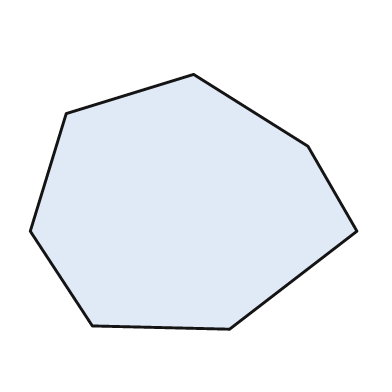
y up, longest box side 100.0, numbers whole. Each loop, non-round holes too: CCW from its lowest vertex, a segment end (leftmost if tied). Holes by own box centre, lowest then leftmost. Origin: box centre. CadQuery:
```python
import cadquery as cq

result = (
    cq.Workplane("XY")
    .moveTo(11.0, -39.0)
    .lineTo(50.0, -9.0)
    .lineTo(35.0, 17.0)
    .lineTo(0.0, 39.0)
    .lineTo(-39.0, 27.0)
    .lineTo(-50.0, -9.0)
    .lineTo(-31.0, -38.0)
    .close()
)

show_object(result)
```